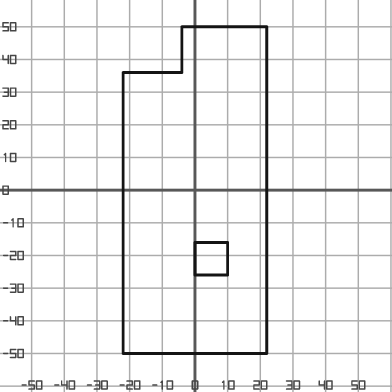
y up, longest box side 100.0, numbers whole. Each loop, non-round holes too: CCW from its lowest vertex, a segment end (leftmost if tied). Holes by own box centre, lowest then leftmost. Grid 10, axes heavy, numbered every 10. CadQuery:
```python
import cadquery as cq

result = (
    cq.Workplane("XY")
    .moveTo(-22.0, -50.0)
    .lineTo(22.0, -50.0)
    .lineTo(22.0, 50.0)
    .lineTo(-4.0, 50.0)
    .lineTo(-4.0, 36.0)
    .lineTo(-22.0, 36.0)
    .close()
    .moveTo(0.0, -26.0)
    .lineTo(10.0, -26.0)
    .lineTo(10.0, -16.0)
    .lineTo(0.0, -16.0)
    .close()
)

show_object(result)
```